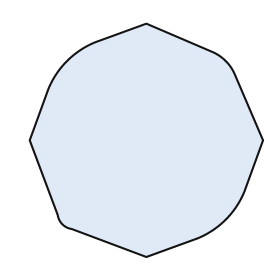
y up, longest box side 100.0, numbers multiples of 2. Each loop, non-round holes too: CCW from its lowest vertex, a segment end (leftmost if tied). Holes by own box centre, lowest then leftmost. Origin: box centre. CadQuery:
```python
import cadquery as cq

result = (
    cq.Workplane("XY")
    .moveTo(0.0, -50.0)
    .lineTo(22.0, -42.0)
    .threePointArc((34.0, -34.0), (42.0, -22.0))
    .lineTo(50.0, 0.0)
    .lineTo(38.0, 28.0)
    .threePointArc((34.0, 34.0), (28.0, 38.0))
    .lineTo(0.0, 50.0)
    .lineTo(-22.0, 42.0)
    .threePointArc((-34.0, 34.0), (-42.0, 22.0))
    .lineTo(-50.0, 0.0)
    .lineTo(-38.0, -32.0)
    .threePointArc((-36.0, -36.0), (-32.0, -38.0))
    .close()
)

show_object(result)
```